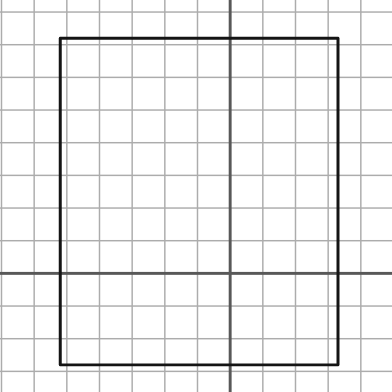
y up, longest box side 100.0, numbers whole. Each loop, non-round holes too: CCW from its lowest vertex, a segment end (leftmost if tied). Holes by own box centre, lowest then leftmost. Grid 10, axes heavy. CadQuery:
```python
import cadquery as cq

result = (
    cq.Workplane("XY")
    .moveTo(-52.0, -28.0)
    .lineTo(33.0, -28.0)
    .lineTo(33.0, 72.0)
    .lineTo(-52.0, 72.0)
    .close()
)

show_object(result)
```